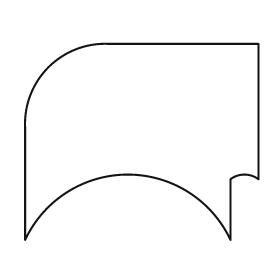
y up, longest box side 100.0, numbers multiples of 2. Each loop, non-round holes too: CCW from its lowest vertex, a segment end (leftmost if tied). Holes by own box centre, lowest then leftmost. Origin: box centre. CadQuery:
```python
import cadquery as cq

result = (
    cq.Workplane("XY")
    .moveTo(-50.0, -42.0)
    .threePointArc((-6.0, -14.0), (38.0, -42.0))
    .lineTo(38.0, -16.0)
    .threePointArc((44.0, -14.0), (50.0, -16.0))
    .lineTo(50.0, 42.0)
    .lineTo(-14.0, 42.0)
    .threePointArc((-40.0, 32.0), (-50.0, 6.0))
    .close()
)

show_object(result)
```